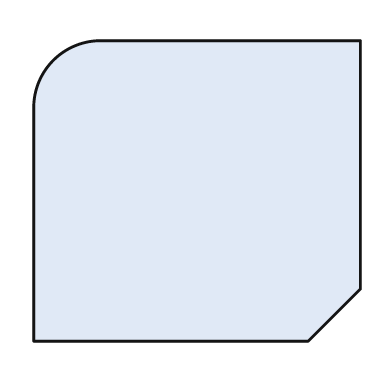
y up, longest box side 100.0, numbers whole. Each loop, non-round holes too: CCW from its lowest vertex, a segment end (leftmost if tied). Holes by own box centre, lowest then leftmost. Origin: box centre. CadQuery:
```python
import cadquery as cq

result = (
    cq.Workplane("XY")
    .moveTo(-50.0, -46.0)
    .lineTo(34.0, -46.0)
    .lineTo(50.0, -30.0)
    .lineTo(50.0, 46.0)
    .lineTo(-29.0, 46.0)
    .threePointArc((-44.0, 40.0), (-50.0, 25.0))
    .close()
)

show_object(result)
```